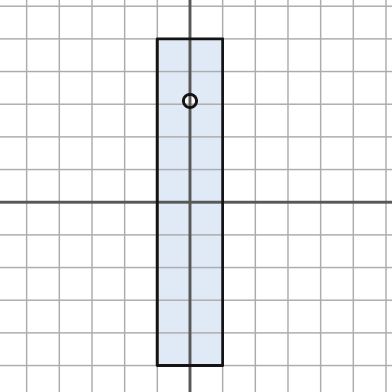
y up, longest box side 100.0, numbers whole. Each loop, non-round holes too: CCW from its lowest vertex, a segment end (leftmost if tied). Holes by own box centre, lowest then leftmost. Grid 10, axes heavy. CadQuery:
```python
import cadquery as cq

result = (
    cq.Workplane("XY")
    .moveTo(-10.0, -50.0)
    .lineTo(10.0, -50.0)
    .lineTo(10.0, 50.0)
    .lineTo(-10.0, 50.0)
    .close()
    .moveTo(0.0, 31.0)
    .circle(2.0)
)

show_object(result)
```